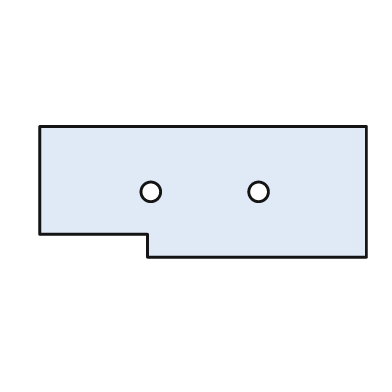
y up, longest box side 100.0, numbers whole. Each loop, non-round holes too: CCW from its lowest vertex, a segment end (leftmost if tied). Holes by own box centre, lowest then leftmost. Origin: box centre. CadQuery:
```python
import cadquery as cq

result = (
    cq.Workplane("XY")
    .moveTo(-17.0, -20.0)
    .lineTo(50.0, -20.0)
    .lineTo(50.0, 20.0)
    .lineTo(-50.0, 20.0)
    .lineTo(-50.0, -13.0)
    .lineTo(-17.0, -13.0)
    .close()
    .moveTo(-16.0, 0.0)
    .circle(3.0)
    .moveTo(17.0, 0.0)
    .circle(3.0)
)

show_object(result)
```